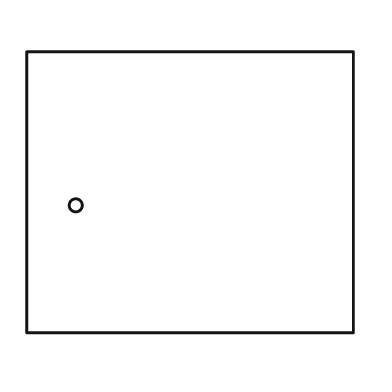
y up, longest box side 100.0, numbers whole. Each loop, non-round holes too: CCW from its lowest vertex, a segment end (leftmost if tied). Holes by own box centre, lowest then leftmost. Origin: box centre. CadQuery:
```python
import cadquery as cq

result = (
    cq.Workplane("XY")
    .moveTo(-50.0, -43.0)
    .lineTo(50.0, -43.0)
    .lineTo(50.0, 43.0)
    .lineTo(-50.0, 43.0)
    .close()
    .moveTo(-35.0, -4.0)
    .circle(2.0)
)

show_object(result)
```